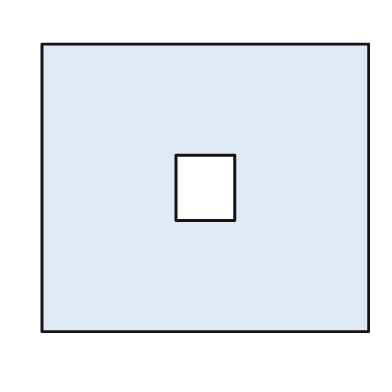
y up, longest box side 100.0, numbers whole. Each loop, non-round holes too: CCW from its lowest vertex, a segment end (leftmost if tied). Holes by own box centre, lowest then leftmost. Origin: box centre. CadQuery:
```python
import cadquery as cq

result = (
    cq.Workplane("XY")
    .moveTo(-50.0, -44.0)
    .lineTo(50.0, -44.0)
    .lineTo(50.0, 44.0)
    .lineTo(-50.0, 44.0)
    .close()
    .moveTo(-9.0, -10.0)
    .lineTo(9.0, -10.0)
    .lineTo(9.0, 10.0)
    .lineTo(-9.0, 10.0)
    .close()
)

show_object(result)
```